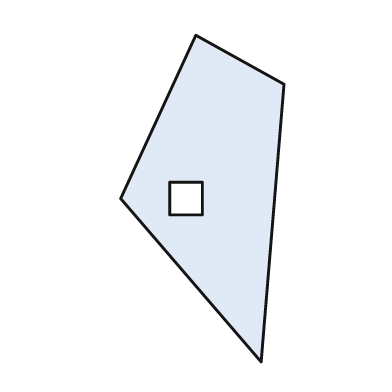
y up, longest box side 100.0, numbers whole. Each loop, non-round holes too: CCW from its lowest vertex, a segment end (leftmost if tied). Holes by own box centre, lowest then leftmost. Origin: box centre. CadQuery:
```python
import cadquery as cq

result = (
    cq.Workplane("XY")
    .moveTo(18.0, -50.0)
    .lineTo(25.0, 35.0)
    .lineTo(-2.0, 50.0)
    .lineTo(-25.0, 0.0)
    .close()
    .moveTo(-10.0, -5.0)
    .lineTo(0.0, -5.0)
    .lineTo(0.0, 5.0)
    .lineTo(-10.0, 5.0)
    .close()
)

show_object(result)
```